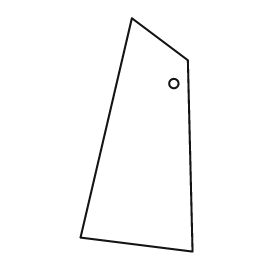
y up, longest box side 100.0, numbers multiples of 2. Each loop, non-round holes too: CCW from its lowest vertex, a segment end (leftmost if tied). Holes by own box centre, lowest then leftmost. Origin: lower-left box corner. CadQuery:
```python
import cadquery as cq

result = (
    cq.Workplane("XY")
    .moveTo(48.0, 0.0)
    .lineTo(46.0, 82.0)
    .lineTo(22.0, 100.0)
    .lineTo(0.0, 6.0)
    .close()
    .moveTo(40.0, 72.0)
    .circle(2.0)
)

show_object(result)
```